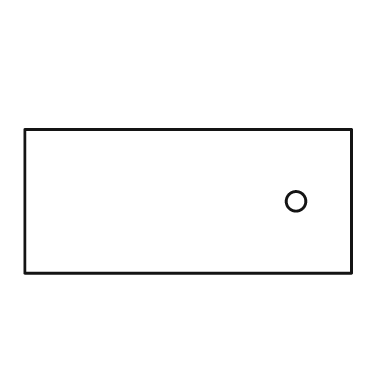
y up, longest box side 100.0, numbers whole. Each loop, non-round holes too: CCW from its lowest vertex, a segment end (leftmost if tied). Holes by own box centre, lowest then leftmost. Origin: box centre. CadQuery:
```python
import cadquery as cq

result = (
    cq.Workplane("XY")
    .moveTo(-50.0, -22.0)
    .lineTo(50.0, -22.0)
    .lineTo(50.0, 22.0)
    .lineTo(-50.0, 22.0)
    .close()
    .moveTo(33.0, 0.0)
    .circle(3.0)
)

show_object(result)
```